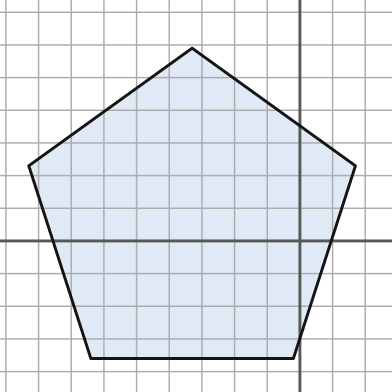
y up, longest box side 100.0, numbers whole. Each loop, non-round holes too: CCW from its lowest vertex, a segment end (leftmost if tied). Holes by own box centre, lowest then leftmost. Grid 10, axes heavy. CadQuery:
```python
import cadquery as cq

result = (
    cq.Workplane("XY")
    .moveTo(-64.0, -36.0)
    .lineTo(-2.0, -36.0)
    .lineTo(17.0, 23.0)
    .lineTo(-33.0, 59.0)
    .lineTo(-83.0, 23.0)
    .close()
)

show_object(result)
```